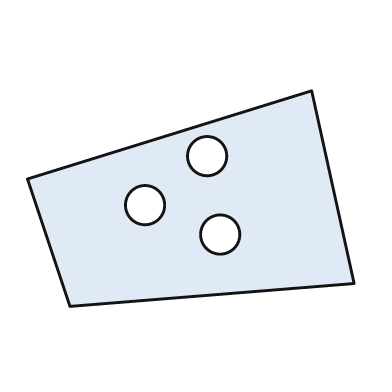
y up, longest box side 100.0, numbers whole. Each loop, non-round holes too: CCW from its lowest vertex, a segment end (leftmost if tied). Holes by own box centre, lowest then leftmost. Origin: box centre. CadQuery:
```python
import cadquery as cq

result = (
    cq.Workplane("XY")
    .moveTo(-37.0, -33.0)
    .lineTo(50.0, -26.0)
    .lineTo(37.0, 33.0)
    .lineTo(-50.0, 6.0)
    .close()
    .moveTo(9.0, -11.0)
    .circle(6.0)
    .moveTo(-14.0, -2.0)
    .circle(6.0)
    .moveTo(5.0, 13.0)
    .circle(6.0)
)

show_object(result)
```